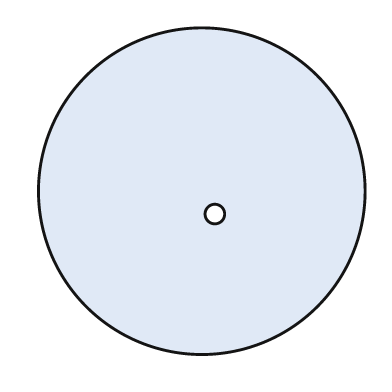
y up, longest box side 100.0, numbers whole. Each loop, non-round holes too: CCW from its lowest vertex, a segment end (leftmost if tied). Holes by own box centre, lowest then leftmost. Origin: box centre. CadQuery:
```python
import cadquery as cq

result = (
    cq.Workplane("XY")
    .moveTo(0.0, 0.0)
    .circle(50.0)
    .moveTo(4.0, -7.0)
    .circle(3.0)
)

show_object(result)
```